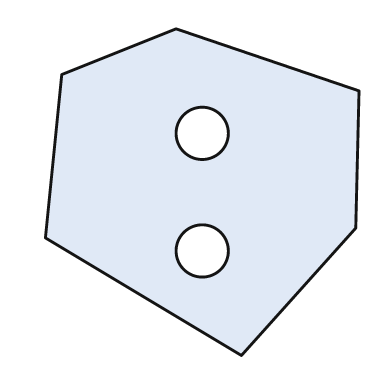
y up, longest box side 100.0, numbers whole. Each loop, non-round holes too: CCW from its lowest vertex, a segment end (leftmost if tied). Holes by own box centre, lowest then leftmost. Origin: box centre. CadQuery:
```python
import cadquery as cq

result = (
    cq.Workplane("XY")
    .moveTo(12.0, -50.0)
    .lineTo(47.0, -11.0)
    .lineTo(48.0, 31.0)
    .lineTo(-8.0, 50.0)
    .lineTo(-43.0, 36.0)
    .lineTo(-48.0, -14.0)
    .close()
    .moveTo(0.0, -18.0)
    .circle(8.0)
    .moveTo(0.0, 18.0)
    .circle(8.0)
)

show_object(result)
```